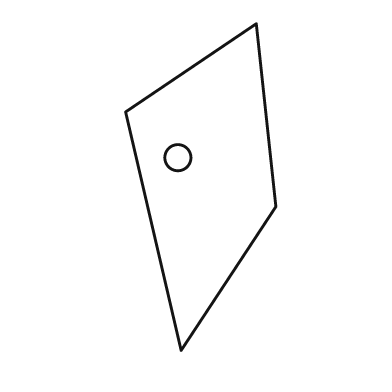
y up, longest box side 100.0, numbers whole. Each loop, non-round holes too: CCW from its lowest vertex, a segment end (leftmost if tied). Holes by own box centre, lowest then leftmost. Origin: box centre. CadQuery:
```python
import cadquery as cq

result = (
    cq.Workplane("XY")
    .moveTo(-6.0, -50.0)
    .lineTo(23.0, -6.0)
    .lineTo(17.0, 50.0)
    .lineTo(-23.0, 23.0)
    .close()
    .moveTo(-7.0, 9.0)
    .circle(4.0)
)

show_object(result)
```